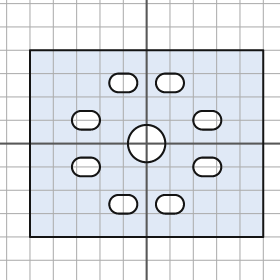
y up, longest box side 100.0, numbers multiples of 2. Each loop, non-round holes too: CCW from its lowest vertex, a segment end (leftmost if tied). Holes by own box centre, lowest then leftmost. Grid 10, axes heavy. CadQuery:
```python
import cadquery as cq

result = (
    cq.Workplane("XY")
    .moveTo(-50.0, -40.0)
    .lineTo(50.0, -40.0)
    .lineTo(50.0, 40.0)
    .lineTo(-50.0, 40.0)
    .close()
    .moveTo(-12.0, -30.0)
    .lineTo(-8.0, -30.0)
    .threePointArc((-4.0, -26.0), (-8.0, -22.0))
    .lineTo(-12.0, -22.0)
    .threePointArc((-16.0, -26.0), (-12.0, -30.0))
    .close()
    .moveTo(8.0, -30.0)
    .lineTo(12.0, -30.0)
    .threePointArc((16.0, -26.0), (12.0, -22.0))
    .lineTo(8.0, -22.0)
    .threePointArc((4.0, -26.0), (8.0, -30.0))
    .close()
    .moveTo(-28.0, -14.0)
    .lineTo(-24.0, -14.0)
    .threePointArc((-20.0, -10.0), (-24.0, -6.0))
    .lineTo(-28.0, -6.0)
    .threePointArc((-32.0, -10.0), (-28.0, -14.0))
    .close()
    .moveTo(24.0, -14.0)
    .lineTo(28.0, -14.0)
    .threePointArc((32.0, -10.0), (28.0, -6.0))
    .lineTo(24.0, -6.0)
    .threePointArc((20.0, -10.0), (24.0, -14.0))
    .close()
    .moveTo(0.0, 0.0)
    .circle(8.0)
    .moveTo(-28.0, 6.0)
    .lineTo(-24.0, 6.0)
    .threePointArc((-20.0, 10.0), (-24.0, 14.0))
    .lineTo(-28.0, 14.0)
    .threePointArc((-32.0, 10.0), (-28.0, 6.0))
    .close()
    .moveTo(24.0, 6.0)
    .lineTo(28.0, 6.0)
    .threePointArc((32.0, 10.0), (28.0, 14.0))
    .lineTo(24.0, 14.0)
    .threePointArc((20.0, 10.0), (24.0, 6.0))
    .close()
    .moveTo(-12.0, 22.0)
    .lineTo(-8.0, 22.0)
    .threePointArc((-4.0, 26.0), (-8.0, 30.0))
    .lineTo(-12.0, 30.0)
    .threePointArc((-16.0, 26.0), (-12.0, 22.0))
    .close()
    .moveTo(8.0, 22.0)
    .lineTo(12.0, 22.0)
    .threePointArc((16.0, 26.0), (12.0, 30.0))
    .lineTo(8.0, 30.0)
    .threePointArc((4.0, 26.0), (8.0, 22.0))
    .close()
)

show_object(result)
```